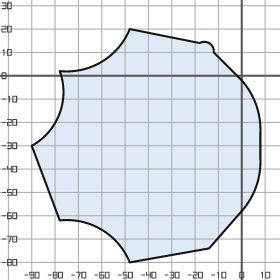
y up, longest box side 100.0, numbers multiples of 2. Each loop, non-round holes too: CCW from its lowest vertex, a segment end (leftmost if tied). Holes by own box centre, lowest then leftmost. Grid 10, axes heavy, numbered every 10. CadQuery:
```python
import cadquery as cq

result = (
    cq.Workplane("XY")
    .moveTo(-48.0, -80.0)
    .lineTo(-14.0, -74.0)
    .lineTo(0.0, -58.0)
    .threePointArc((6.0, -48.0), (8.0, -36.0))
    .lineTo(8.0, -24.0)
    .threePointArc((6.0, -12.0), (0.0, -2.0))
    .lineTo(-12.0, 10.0)
    .threePointArc((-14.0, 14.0), (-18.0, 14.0))
    .lineTo(-48.0, 20.0)
    .threePointArc((-60.0, 6.0), (-78.0, 2.0))
    .threePointArc((-78.0, -16.0), (-90.0, -30.0))
    .lineTo(-78.0, -62.0)
    .threePointArc((-60.0, -66.0), (-48.0, -80.0))
    .close()
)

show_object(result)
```